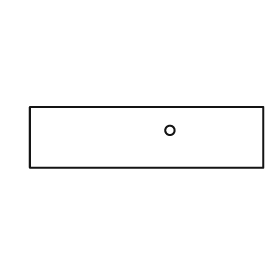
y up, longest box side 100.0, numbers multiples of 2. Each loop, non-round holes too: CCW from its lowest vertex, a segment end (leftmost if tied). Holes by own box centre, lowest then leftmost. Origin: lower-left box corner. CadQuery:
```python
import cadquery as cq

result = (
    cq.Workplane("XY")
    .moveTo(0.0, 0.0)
    .lineTo(100.0, 0.0)
    .lineTo(100.0, 26.0)
    .lineTo(0.0, 26.0)
    .close()
    .moveTo(60.0, 16.0)
    .circle(2.0)
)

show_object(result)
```